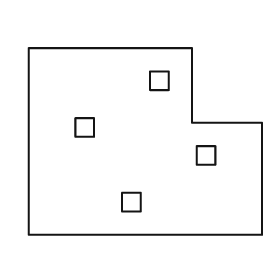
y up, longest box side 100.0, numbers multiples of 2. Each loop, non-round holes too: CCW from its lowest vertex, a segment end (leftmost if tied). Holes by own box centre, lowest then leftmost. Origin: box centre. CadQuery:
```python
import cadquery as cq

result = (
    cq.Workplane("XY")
    .moveTo(-50.0, -40.0)
    .lineTo(50.0, -40.0)
    .lineTo(50.0, 8.0)
    .lineTo(20.0, 8.0)
    .lineTo(20.0, 40.0)
    .lineTo(-50.0, 40.0)
    .close()
    .moveTo(-10.0, -30.0)
    .lineTo(-2.0, -30.0)
    .lineTo(-2.0, -22.0)
    .lineTo(-10.0, -22.0)
    .close()
    .moveTo(22.0, -10.0)
    .lineTo(30.0, -10.0)
    .lineTo(30.0, -2.0)
    .lineTo(22.0, -2.0)
    .close()
    .moveTo(-30.0, 2.0)
    .lineTo(-22.0, 2.0)
    .lineTo(-22.0, 10.0)
    .lineTo(-30.0, 10.0)
    .close()
    .moveTo(2.0, 22.0)
    .lineTo(10.0, 22.0)
    .lineTo(10.0, 30.0)
    .lineTo(2.0, 30.0)
    .close()
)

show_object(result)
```